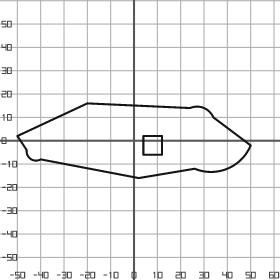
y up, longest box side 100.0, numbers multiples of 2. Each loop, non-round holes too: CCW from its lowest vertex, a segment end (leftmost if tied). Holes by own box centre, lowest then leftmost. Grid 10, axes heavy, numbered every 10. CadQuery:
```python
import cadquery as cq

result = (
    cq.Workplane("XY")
    .moveTo(2.0, -16.0)
    .lineTo(26.0, -12.0)
    .threePointArc((40.0, -12.0), (50.0, -2.0))
    .lineTo(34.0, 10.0)
    .threePointArc((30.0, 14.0), (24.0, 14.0))
    .lineTo(-20.0, 16.0)
    .lineTo(-50.0, 2.0)
    .lineTo(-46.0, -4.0)
    .threePointArc((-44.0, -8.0), (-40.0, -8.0))
    .close()
    .moveTo(4.0, -6.0)
    .lineTo(12.0, -6.0)
    .lineTo(12.0, 2.0)
    .lineTo(4.0, 2.0)
    .close()
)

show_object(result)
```